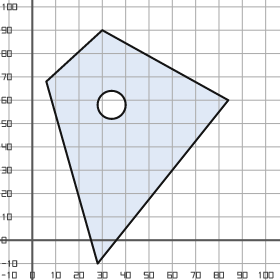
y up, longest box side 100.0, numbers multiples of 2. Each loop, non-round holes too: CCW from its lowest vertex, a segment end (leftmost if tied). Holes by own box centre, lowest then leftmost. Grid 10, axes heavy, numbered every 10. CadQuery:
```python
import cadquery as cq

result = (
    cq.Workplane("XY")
    .moveTo(28.0, -10.0)
    .lineTo(84.0, 60.0)
    .lineTo(30.0, 90.0)
    .lineTo(6.0, 68.0)
    .close()
    .moveTo(34.0, 58.0)
    .circle(6.0)
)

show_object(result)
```